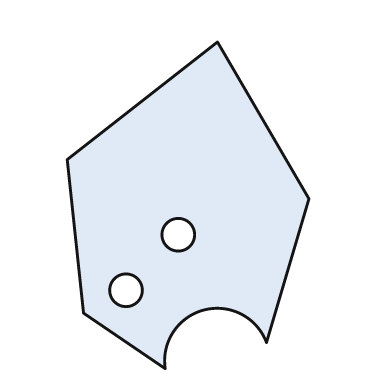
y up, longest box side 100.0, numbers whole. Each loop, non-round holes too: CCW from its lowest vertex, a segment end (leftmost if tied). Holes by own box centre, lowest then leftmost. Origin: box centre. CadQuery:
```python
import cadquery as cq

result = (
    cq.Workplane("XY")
    .moveTo(-7.0, -50.0)
    .threePointArc((5.0, -32.0), (24.0, -42.0))
    .lineTo(37.0, 2.0)
    .lineTo(9.0, 50.0)
    .lineTo(-37.0, 14.0)
    .lineTo(-32.0, -33.0)
    .close()
    .moveTo(-19.0, -26.0)
    .circle(5.0)
    .moveTo(-3.0, -9.0)
    .circle(5.0)
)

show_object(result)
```